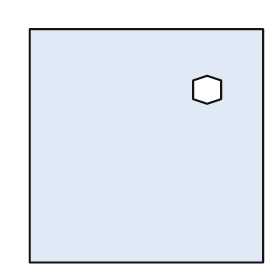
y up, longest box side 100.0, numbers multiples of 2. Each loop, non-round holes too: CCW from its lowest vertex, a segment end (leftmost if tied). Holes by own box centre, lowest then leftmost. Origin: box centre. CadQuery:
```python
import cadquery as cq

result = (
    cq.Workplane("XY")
    .moveTo(-50.0, -50.0)
    .lineTo(50.0, -50.0)
    .lineTo(50.0, 50.0)
    .lineTo(-50.0, 50.0)
    .close()
    .moveTo(26.0, 18.0)
    .lineTo(32.0, 20.0)
    .lineTo(32.0, 28.0)
    .lineTo(26.0, 30.0)
    .lineTo(20.0, 28.0)
    .lineTo(20.0, 20.0)
    .close()
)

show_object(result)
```